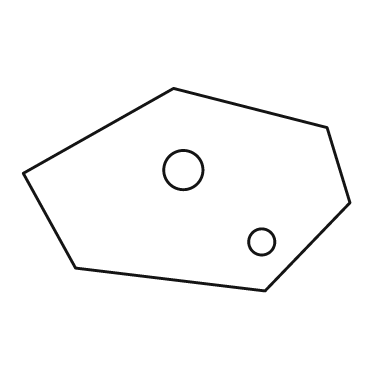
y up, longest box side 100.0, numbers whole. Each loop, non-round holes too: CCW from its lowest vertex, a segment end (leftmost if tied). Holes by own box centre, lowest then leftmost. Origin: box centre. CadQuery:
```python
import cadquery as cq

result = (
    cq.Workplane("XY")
    .moveTo(24.0, -31.0)
    .lineTo(50.0, -4.0)
    .lineTo(43.0, 19.0)
    .lineTo(-4.0, 31.0)
    .lineTo(-50.0, 5.0)
    .lineTo(-34.0, -24.0)
    .close()
    .moveTo(23.0, -16.0)
    .circle(4.0)
    .moveTo(-1.0, 6.0)
    .circle(6.0)
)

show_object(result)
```